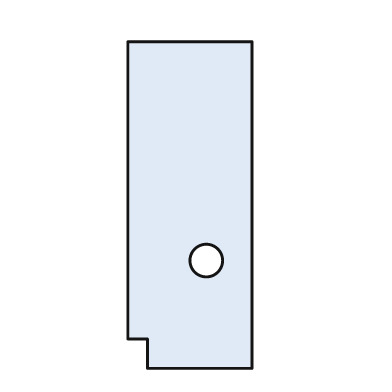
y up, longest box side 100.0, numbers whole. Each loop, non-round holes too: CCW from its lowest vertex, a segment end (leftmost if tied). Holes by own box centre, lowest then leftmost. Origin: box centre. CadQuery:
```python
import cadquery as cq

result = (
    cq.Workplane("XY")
    .moveTo(-13.0, -50.0)
    .lineTo(19.0, -50.0)
    .lineTo(19.0, 50.0)
    .lineTo(-19.0, 50.0)
    .lineTo(-19.0, -41.0)
    .lineTo(-13.0, -41.0)
    .close()
    .moveTo(5.0, -17.0)
    .circle(5.0)
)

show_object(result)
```